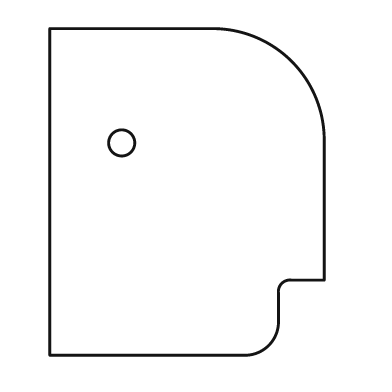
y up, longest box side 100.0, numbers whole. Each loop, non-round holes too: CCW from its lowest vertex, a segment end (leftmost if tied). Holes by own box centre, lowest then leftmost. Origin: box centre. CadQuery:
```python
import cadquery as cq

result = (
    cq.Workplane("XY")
    .moveTo(-42.0, -50.0)
    .lineTo(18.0, -50.0)
    .threePointArc((25.0, -47.0), (28.0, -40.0))
    .lineTo(28.0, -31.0)
    .threePointArc((29.0, -28.0), (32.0, -27.0))
    .lineTo(42.0, -27.0)
    .lineTo(42.0, 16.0)
    .threePointArc((32.0, 40.0), (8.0, 50.0))
    .lineTo(-42.0, 50.0)
    .close()
    .moveTo(-20.0, 15.0)
    .circle(4.0)
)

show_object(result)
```